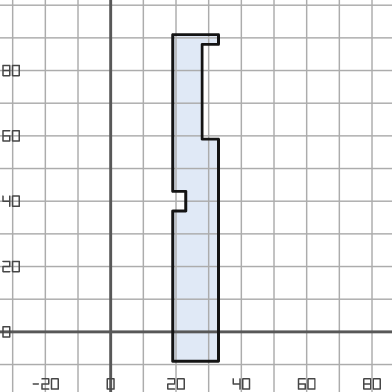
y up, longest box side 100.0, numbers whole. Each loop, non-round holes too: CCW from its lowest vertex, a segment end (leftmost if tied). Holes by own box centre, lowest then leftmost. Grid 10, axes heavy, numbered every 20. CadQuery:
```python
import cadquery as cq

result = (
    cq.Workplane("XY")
    .moveTo(19.0, -9.0)
    .lineTo(33.0, -9.0)
    .lineTo(33.0, 59.0)
    .lineTo(28.0, 59.0)
    .lineTo(28.0, 88.0)
    .lineTo(33.0, 88.0)
    .lineTo(33.0, 91.0)
    .lineTo(19.0, 91.0)
    .lineTo(19.0, 43.0)
    .lineTo(23.0, 43.0)
    .lineTo(23.0, 37.0)
    .lineTo(19.0, 37.0)
    .close()
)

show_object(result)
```